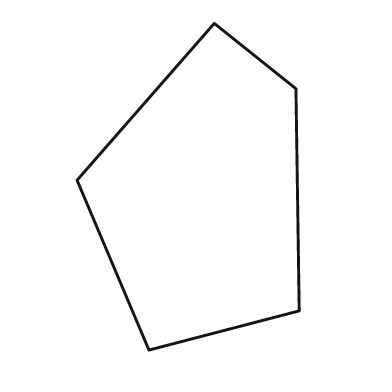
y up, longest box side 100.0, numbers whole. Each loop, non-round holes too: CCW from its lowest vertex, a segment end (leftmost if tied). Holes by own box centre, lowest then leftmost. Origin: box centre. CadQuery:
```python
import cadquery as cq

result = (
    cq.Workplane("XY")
    .moveTo(-12.0, -50.0)
    .lineTo(34.0, -38.0)
    .lineTo(33.0, 30.0)
    .lineTo(8.0, 50.0)
    .lineTo(-34.0, 2.0)
    .close()
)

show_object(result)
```